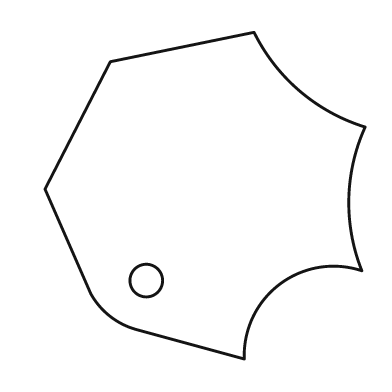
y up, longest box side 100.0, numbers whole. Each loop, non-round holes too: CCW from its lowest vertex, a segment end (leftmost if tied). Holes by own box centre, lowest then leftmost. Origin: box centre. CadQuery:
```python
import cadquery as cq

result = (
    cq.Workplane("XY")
    .moveTo(12.0, -50.0)
    .threePointArc((23.0, -27.0), (48.0, -23.0))
    .threePointArc((44.0, -1.0), (49.0, 21.0))
    .threePointArc((29.0, 32.0), (15.0, 50.0))
    .lineTo(-29.0, 41.0)
    .lineTo(-49.0, 2.0)
    .lineTo(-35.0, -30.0)
    .threePointArc((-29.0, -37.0), (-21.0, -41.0))
    .close()
    .moveTo(-18.0, -26.0)
    .circle(5.0)
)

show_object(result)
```